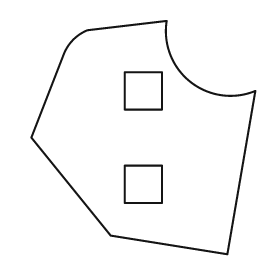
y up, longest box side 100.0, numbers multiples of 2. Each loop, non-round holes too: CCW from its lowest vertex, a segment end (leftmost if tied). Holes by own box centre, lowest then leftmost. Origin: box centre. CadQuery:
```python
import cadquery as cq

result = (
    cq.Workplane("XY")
    .moveTo(36.0, -50.0)
    .lineTo(48.0, 20.0)
    .threePointArc((20.0, 24.0), (10.0, 50.0))
    .lineTo(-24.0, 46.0)
    .threePointArc((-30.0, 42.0), (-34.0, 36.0))
    .lineTo(-48.0, 0.0)
    .lineTo(-14.0, -42.0)
    .close()
    .moveTo(-8.0, -28.0)
    .lineTo(8.0, -28.0)
    .lineTo(8.0, -12.0)
    .lineTo(-8.0, -12.0)
    .close()
    .moveTo(-8.0, 12.0)
    .lineTo(8.0, 12.0)
    .lineTo(8.0, 28.0)
    .lineTo(-8.0, 28.0)
    .close()
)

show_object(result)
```